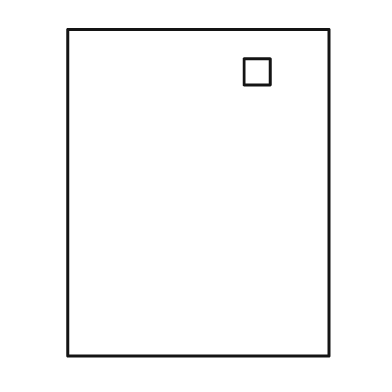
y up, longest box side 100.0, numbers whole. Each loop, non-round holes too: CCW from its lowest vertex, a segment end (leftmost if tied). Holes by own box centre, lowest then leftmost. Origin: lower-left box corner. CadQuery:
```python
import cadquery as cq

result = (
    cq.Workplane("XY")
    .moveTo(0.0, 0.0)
    .lineTo(80.0, 0.0)
    .lineTo(80.0, 100.0)
    .lineTo(0.0, 100.0)
    .close()
    .moveTo(54.0, 83.0)
    .lineTo(62.0, 83.0)
    .lineTo(62.0, 91.0)
    .lineTo(54.0, 91.0)
    .close()
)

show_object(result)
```